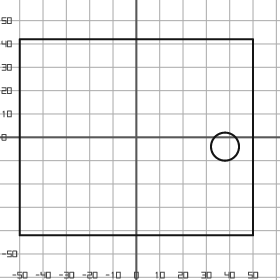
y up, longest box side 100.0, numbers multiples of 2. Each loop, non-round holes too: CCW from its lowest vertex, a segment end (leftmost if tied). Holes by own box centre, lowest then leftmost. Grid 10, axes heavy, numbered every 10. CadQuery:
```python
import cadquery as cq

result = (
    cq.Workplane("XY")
    .moveTo(-50.0, -42.0)
    .lineTo(50.0, -42.0)
    .lineTo(50.0, 42.0)
    .lineTo(-50.0, 42.0)
    .close()
    .moveTo(38.0, -4.0)
    .circle(6.0)
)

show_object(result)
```